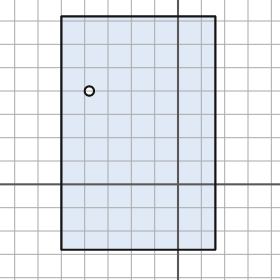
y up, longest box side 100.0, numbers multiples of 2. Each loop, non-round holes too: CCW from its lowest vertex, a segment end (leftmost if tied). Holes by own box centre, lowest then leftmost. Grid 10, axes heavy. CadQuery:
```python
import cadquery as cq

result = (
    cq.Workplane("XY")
    .moveTo(-50.0, -28.0)
    .lineTo(16.0, -28.0)
    .lineTo(16.0, 72.0)
    .lineTo(-50.0, 72.0)
    .close()
    .moveTo(-38.0, 40.0)
    .circle(2.0)
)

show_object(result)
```